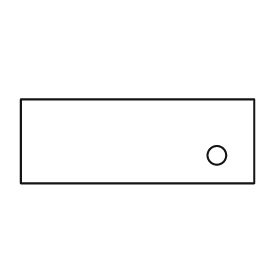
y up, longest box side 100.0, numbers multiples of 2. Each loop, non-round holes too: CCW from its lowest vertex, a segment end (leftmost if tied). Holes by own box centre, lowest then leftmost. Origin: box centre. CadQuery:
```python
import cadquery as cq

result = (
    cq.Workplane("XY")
    .moveTo(-50.0, -18.0)
    .lineTo(50.0, -18.0)
    .lineTo(50.0, 18.0)
    .lineTo(-50.0, 18.0)
    .close()
    .moveTo(34.0, -6.0)
    .circle(4.0)
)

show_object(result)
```